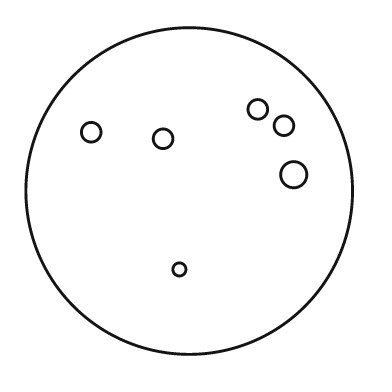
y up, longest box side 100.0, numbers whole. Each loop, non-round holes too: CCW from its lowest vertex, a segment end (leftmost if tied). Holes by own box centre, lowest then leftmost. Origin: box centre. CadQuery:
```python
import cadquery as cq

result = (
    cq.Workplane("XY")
    .moveTo(0.0, 0.0)
    .circle(50.0)
    .moveTo(-3.0, -24.0)
    .circle(2.0)
    .moveTo(32.0, 5.0)
    .circle(4.0)
    .moveTo(-8.0, 16.0)
    .circle(3.0)
    .moveTo(-30.0, 18.0)
    .circle(3.0)
    .moveTo(29.0, 20.0)
    .circle(3.0)
    .moveTo(21.0, 25.0)
    .circle(3.0)
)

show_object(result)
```